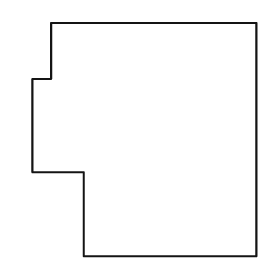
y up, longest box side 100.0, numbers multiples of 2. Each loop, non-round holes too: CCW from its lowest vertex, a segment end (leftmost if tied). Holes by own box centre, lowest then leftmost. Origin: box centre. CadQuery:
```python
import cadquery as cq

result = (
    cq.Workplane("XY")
    .moveTo(-26.0, -50.0)
    .lineTo(48.0, -50.0)
    .lineTo(48.0, 50.0)
    .lineTo(-40.0, 50.0)
    .lineTo(-40.0, 26.0)
    .lineTo(-48.0, 26.0)
    .lineTo(-48.0, -14.0)
    .lineTo(-26.0, -14.0)
    .close()
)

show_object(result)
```